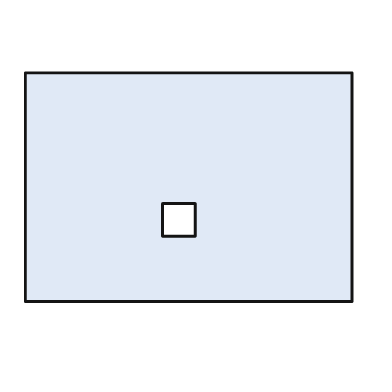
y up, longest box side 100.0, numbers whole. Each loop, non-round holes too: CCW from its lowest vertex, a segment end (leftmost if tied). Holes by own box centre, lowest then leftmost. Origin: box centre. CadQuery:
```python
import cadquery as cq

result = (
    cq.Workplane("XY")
    .moveTo(-50.0, -35.0)
    .lineTo(50.0, -35.0)
    .lineTo(50.0, 35.0)
    .lineTo(-50.0, 35.0)
    .close()
    .moveTo(-8.0, -15.0)
    .lineTo(2.0, -15.0)
    .lineTo(2.0, -5.0)
    .lineTo(-8.0, -5.0)
    .close()
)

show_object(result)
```